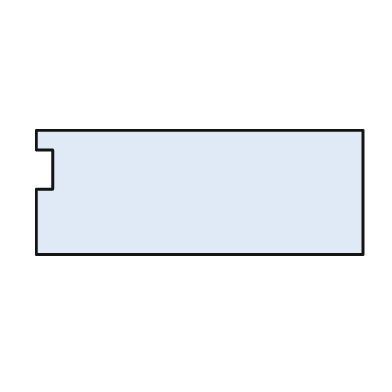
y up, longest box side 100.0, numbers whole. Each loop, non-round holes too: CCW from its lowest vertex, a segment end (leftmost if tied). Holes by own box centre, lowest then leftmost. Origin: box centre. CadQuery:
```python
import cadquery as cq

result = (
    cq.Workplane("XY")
    .moveTo(-50.0, -19.0)
    .lineTo(50.0, -19.0)
    .lineTo(50.0, 19.0)
    .lineTo(-50.0, 19.0)
    .lineTo(-50.0, 13.0)
    .lineTo(-45.0, 13.0)
    .lineTo(-45.0, 1.0)
    .lineTo(-50.0, 1.0)
    .close()
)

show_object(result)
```